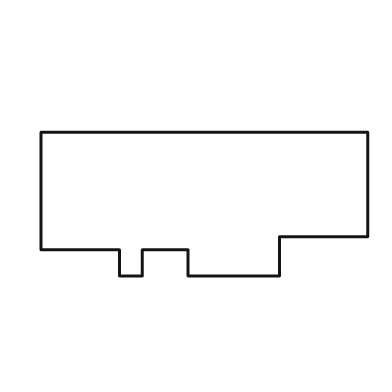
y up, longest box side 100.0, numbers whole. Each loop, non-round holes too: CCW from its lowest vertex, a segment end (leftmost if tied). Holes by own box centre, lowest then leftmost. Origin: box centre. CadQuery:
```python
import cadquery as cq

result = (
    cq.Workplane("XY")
    .moveTo(-26.0, -22.0)
    .lineTo(-19.0, -22.0)
    .lineTo(-19.0, -14.0)
    .lineTo(-5.0, -14.0)
    .lineTo(-5.0, -22.0)
    .lineTo(23.0, -22.0)
    .lineTo(23.0, -10.0)
    .lineTo(50.0, -10.0)
    .lineTo(50.0, 22.0)
    .lineTo(-50.0, 22.0)
    .lineTo(-50.0, -14.0)
    .lineTo(-26.0, -14.0)
    .close()
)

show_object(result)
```